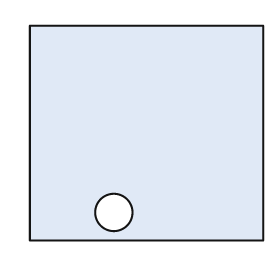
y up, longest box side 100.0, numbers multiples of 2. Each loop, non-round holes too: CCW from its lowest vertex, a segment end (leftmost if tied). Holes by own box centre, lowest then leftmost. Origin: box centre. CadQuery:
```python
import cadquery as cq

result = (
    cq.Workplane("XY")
    .moveTo(-50.0, -46.0)
    .lineTo(50.0, -46.0)
    .lineTo(50.0, 46.0)
    .lineTo(-50.0, 46.0)
    .close()
    .moveTo(-14.0, -34.0)
    .circle(8.0)
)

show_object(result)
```